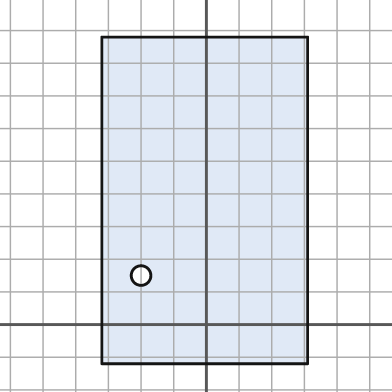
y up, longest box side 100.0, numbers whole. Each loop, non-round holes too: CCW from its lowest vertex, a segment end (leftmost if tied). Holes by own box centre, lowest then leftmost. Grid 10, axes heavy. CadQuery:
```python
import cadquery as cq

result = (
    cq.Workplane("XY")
    .moveTo(-32.0, -12.0)
    .lineTo(31.0, -12.0)
    .lineTo(31.0, 88.0)
    .lineTo(-32.0, 88.0)
    .close()
    .moveTo(-20.0, 15.0)
    .circle(3.0)
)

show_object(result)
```